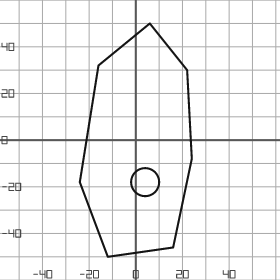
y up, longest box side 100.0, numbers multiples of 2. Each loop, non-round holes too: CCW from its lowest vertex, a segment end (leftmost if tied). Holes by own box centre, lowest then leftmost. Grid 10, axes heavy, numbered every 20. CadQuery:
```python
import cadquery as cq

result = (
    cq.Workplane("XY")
    .moveTo(-12.0, -50.0)
    .lineTo(16.0, -46.0)
    .lineTo(24.0, -8.0)
    .lineTo(22.0, 30.0)
    .lineTo(6.0, 50.0)
    .lineTo(-16.0, 32.0)
    .lineTo(-24.0, -18.0)
    .close()
    .moveTo(4.0, -18.0)
    .circle(6.0)
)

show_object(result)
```